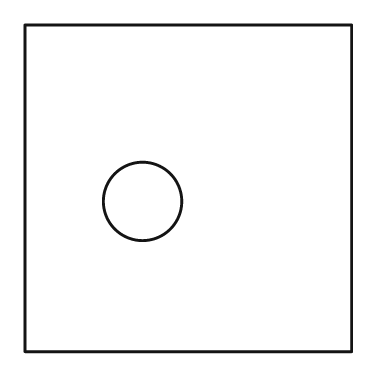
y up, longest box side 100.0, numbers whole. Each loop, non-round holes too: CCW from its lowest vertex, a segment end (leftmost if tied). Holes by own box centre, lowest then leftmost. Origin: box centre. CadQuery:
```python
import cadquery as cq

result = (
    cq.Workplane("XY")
    .moveTo(-50.0, -50.0)
    .lineTo(50.0, -50.0)
    .lineTo(50.0, 50.0)
    .lineTo(-50.0, 50.0)
    .close()
    .moveTo(-14.0, -4.0)
    .circle(12.0)
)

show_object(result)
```